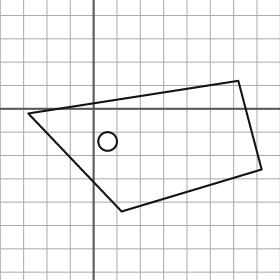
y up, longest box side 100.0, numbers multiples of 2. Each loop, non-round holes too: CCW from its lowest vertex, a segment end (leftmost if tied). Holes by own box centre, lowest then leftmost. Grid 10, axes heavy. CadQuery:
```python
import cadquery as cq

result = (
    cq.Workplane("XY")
    .moveTo(12.0, -44.0)
    .lineTo(72.0, -26.0)
    .lineTo(62.0, 12.0)
    .lineTo(-28.0, -2.0)
    .close()
    .moveTo(6.0, -14.0)
    .circle(4.0)
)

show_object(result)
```